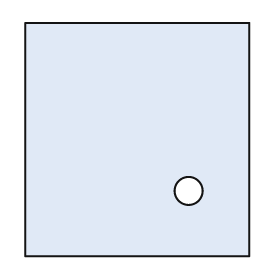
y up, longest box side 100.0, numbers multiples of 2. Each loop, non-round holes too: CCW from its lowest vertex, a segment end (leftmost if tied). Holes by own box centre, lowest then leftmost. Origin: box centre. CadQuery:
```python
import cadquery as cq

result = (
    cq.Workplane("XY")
    .moveTo(-48.0, -50.0)
    .lineTo(48.0, -50.0)
    .lineTo(48.0, 50.0)
    .lineTo(-48.0, 50.0)
    .close()
    .moveTo(22.0, -22.0)
    .circle(6.0)
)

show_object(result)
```